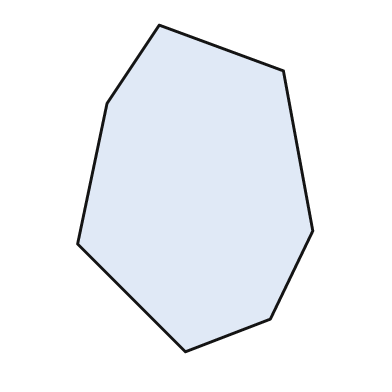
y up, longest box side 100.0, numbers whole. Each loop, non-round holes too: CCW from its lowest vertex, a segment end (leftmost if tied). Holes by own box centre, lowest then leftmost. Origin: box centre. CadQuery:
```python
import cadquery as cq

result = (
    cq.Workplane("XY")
    .moveTo(-3.0, -50.0)
    .lineTo(23.0, -40.0)
    .lineTo(36.0, -13.0)
    .lineTo(27.0, 36.0)
    .lineTo(-11.0, 50.0)
    .lineTo(-27.0, 26.0)
    .lineTo(-36.0, -17.0)
    .close()
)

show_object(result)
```